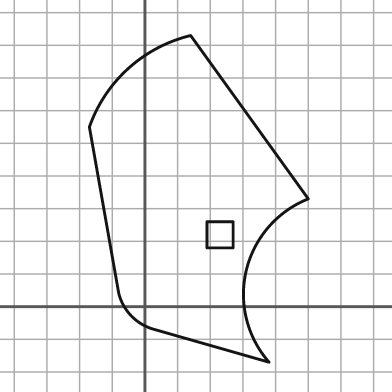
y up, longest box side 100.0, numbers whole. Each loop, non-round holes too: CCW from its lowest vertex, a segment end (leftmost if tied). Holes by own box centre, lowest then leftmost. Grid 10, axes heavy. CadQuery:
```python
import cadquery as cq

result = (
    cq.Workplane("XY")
    .moveTo(38.0, -17.0)
    .threePointArc((31.0, 11.0), (50.0, 33.0))
    .lineTo(14.0, 83.0)
    .threePointArc((-5.0, 73.0), (-17.0, 55.0))
    .lineTo(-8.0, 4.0)
    .threePointArc((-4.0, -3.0), (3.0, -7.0))
    .close()
    .moveTo(19.0, 18.0)
    .lineTo(27.0, 18.0)
    .lineTo(27.0, 26.0)
    .lineTo(19.0, 26.0)
    .close()
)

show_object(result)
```